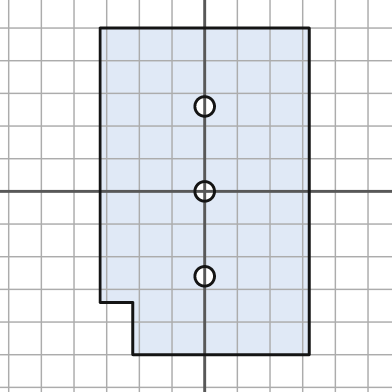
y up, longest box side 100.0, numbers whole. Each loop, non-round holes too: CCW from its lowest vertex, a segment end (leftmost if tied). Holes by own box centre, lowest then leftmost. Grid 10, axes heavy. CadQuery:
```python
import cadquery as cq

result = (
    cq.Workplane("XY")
    .moveTo(-22.0, -50.0)
    .lineTo(32.0, -50.0)
    .lineTo(32.0, 50.0)
    .lineTo(-32.0, 50.0)
    .lineTo(-32.0, -34.0)
    .lineTo(-22.0, -34.0)
    .close()
    .moveTo(0.0, -26.0)
    .circle(3.0)
    .moveTo(0.0, 0.0)
    .circle(3.0)
    .moveTo(0.0, 26.0)
    .circle(3.0)
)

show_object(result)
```